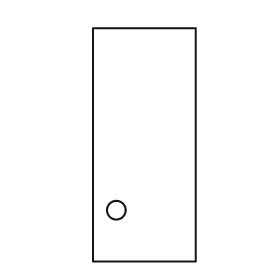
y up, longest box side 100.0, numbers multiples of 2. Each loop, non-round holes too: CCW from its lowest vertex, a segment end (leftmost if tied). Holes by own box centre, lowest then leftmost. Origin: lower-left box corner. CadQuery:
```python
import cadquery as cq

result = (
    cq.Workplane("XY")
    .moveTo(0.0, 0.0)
    .lineTo(44.0, 0.0)
    .lineTo(44.0, 100.0)
    .lineTo(0.0, 100.0)
    .close()
    .moveTo(10.0, 22.0)
    .circle(4.0)
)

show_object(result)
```